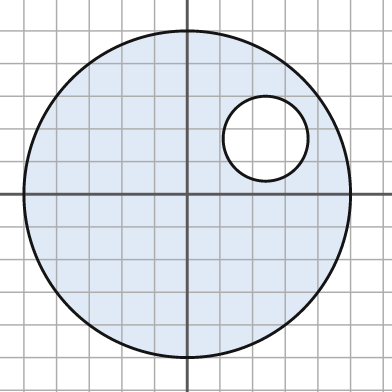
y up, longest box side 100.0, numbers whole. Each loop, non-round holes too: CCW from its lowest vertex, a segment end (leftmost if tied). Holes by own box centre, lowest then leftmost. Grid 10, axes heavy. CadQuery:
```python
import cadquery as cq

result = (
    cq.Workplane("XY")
    .moveTo(0.0, 0.0)
    .circle(50.0)
    .moveTo(24.0, 17.0)
    .circle(13.0)
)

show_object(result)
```